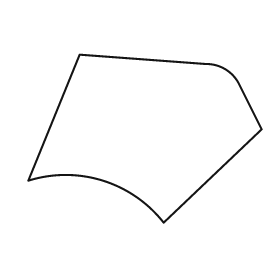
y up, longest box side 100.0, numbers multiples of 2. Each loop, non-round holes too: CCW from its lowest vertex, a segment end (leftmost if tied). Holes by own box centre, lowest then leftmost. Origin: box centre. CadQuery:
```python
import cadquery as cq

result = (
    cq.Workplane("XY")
    .moveTo(8.0, -36.0)
    .lineTo(50.0, 4.0)
    .lineTo(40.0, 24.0)
    .threePointArc((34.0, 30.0), (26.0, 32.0))
    .lineTo(-28.0, 36.0)
    .lineTo(-50.0, -18.0)
    .threePointArc((-18.0, -18.0), (8.0, -36.0))
    .close()
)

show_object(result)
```